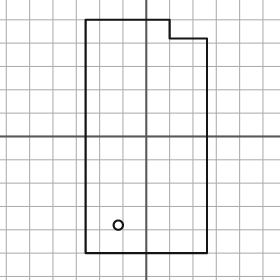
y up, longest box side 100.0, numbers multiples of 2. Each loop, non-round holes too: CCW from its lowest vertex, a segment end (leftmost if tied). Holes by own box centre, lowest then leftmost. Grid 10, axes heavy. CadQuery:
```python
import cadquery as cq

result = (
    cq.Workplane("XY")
    .moveTo(-26.0, -50.0)
    .lineTo(26.0, -50.0)
    .lineTo(26.0, 42.0)
    .lineTo(10.0, 42.0)
    .lineTo(10.0, 50.0)
    .lineTo(-26.0, 50.0)
    .close()
    .moveTo(-12.0, -38.0)
    .circle(2.0)
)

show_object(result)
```